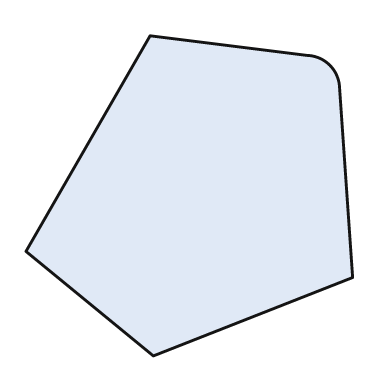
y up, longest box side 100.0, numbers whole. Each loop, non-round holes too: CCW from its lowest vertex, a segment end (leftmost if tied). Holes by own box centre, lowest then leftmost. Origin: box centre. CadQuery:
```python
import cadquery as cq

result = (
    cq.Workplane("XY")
    .moveTo(-11.0, -49.0)
    .lineTo(50.0, -25.0)
    .lineTo(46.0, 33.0)
    .threePointArc((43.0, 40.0), (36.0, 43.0))
    .lineTo(-12.0, 49.0)
    .lineTo(-50.0, -17.0)
    .close()
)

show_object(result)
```